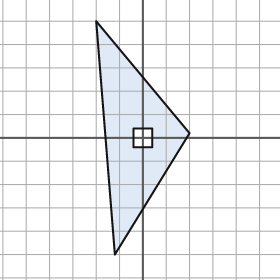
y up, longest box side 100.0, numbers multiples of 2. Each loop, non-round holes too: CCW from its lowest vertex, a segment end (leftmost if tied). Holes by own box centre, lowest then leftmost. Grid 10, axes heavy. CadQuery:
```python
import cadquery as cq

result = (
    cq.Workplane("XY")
    .moveTo(-12.0, -50.0)
    .lineTo(20.0, 2.0)
    .lineTo(-20.0, 50.0)
    .close()
    .moveTo(-4.0, -4.0)
    .lineTo(4.0, -4.0)
    .lineTo(4.0, 4.0)
    .lineTo(-4.0, 4.0)
    .close()
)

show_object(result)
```